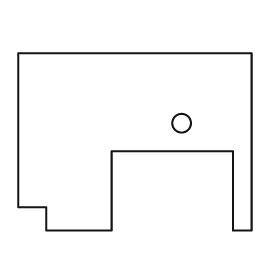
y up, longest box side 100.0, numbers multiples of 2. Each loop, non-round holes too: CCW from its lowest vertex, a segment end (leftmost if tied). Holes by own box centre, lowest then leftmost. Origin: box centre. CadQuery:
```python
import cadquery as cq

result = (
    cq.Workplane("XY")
    .moveTo(-38.0, -38.0)
    .lineTo(-10.0, -38.0)
    .lineTo(-10.0, -4.0)
    .lineTo(42.0, -4.0)
    .lineTo(42.0, -38.0)
    .lineTo(50.0, -38.0)
    .lineTo(50.0, 38.0)
    .lineTo(-50.0, 38.0)
    .lineTo(-50.0, -28.0)
    .lineTo(-38.0, -28.0)
    .close()
    .moveTo(20.0, 8.0)
    .circle(4.0)
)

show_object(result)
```